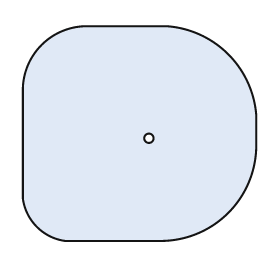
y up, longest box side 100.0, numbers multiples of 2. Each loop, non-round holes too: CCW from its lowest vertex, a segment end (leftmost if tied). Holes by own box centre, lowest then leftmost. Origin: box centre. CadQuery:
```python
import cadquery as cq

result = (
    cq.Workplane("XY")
    .moveTo(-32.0, -46.0)
    .lineTo(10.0, -46.0)
    .threePointArc((38.0, -34.0), (50.0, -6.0))
    .lineTo(50.0, 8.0)
    .threePointArc((38.0, 34.0), (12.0, 46.0))
    .lineTo(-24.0, 46.0)
    .threePointArc((-42.0, 38.0), (-50.0, 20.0))
    .lineTo(-50.0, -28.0)
    .threePointArc((-44.0, -40.0), (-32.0, -46.0))
    .close()
    .moveTo(4.0, -2.0)
    .circle(2.0)
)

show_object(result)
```